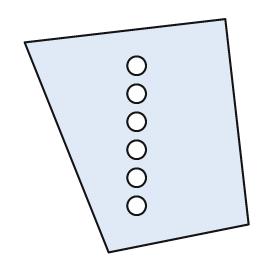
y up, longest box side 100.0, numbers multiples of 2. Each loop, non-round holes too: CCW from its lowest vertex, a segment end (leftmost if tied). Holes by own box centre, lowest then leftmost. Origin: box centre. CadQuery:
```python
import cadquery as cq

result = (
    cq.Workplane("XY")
    .moveTo(-12.0, -50.0)
    .lineTo(48.0, -38.0)
    .lineTo(38.0, 50.0)
    .lineTo(-48.0, 40.0)
    .close()
    .moveTo(0.0, -30.0)
    .circle(4.0)
    .moveTo(0.0, -18.0)
    .circle(4.0)
    .moveTo(0.0, -6.0)
    .circle(4.0)
    .moveTo(0.0, 6.0)
    .circle(4.0)
    .moveTo(0.0, 18.0)
    .circle(4.0)
    .moveTo(0.0, 30.0)
    .circle(4.0)
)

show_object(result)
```